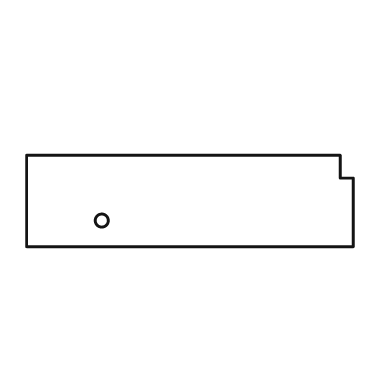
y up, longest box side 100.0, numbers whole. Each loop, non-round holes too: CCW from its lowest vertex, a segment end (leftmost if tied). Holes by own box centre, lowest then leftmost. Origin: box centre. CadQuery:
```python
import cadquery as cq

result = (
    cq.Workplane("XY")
    .moveTo(-50.0, -14.0)
    .lineTo(50.0, -14.0)
    .lineTo(50.0, 7.0)
    .lineTo(46.0, 7.0)
    .lineTo(46.0, 14.0)
    .lineTo(-50.0, 14.0)
    .close()
    .moveTo(-27.0, -6.0)
    .circle(2.0)
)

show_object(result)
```